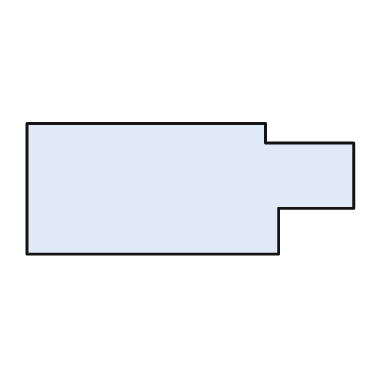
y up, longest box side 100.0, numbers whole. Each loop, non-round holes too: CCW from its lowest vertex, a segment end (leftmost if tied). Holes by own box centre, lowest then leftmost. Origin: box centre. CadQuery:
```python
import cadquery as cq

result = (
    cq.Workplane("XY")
    .moveTo(-50.0, -20.0)
    .lineTo(27.0, -20.0)
    .lineTo(27.0, -6.0)
    .lineTo(50.0, -6.0)
    .lineTo(50.0, 14.0)
    .lineTo(23.0, 14.0)
    .lineTo(23.0, 20.0)
    .lineTo(-50.0, 20.0)
    .close()
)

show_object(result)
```